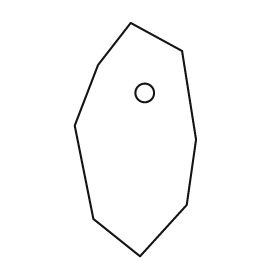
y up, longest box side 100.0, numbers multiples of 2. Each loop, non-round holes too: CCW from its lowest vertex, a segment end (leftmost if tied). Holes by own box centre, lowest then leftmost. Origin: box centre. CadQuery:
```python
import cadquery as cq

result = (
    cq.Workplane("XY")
    .moveTo(2.0, -50.0)
    .lineTo(22.0, -28.0)
    .lineTo(26.0, 0.0)
    .lineTo(20.0, 38.0)
    .lineTo(-2.0, 50.0)
    .lineTo(-16.0, 32.0)
    .lineTo(-26.0, 6.0)
    .lineTo(-18.0, -34.0)
    .close()
    .moveTo(4.0, 20.0)
    .circle(4.0)
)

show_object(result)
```